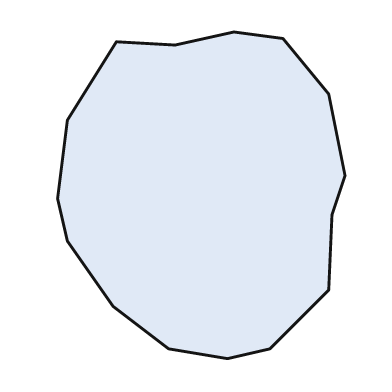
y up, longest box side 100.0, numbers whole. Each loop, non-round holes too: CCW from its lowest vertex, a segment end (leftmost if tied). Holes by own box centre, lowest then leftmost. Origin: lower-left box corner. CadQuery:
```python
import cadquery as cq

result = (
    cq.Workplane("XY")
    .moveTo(52.0, 0.0)
    .lineTo(65.0, 3.0)
    .lineTo(83.0, 21.0)
    .lineTo(84.0, 44.0)
    .lineTo(88.0, 56.0)
    .lineTo(83.0, 81.0)
    .lineTo(69.0, 98.0)
    .lineTo(54.0, 100.0)
    .lineTo(36.0, 96.0)
    .lineTo(18.0, 97.0)
    .lineTo(3.0, 73.0)
    .lineTo(0.0, 49.0)
    .lineTo(3.0, 36.0)
    .lineTo(17.0, 16.0)
    .lineTo(34.0, 3.0)
    .close()
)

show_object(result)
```